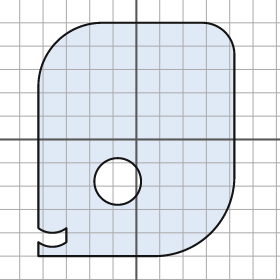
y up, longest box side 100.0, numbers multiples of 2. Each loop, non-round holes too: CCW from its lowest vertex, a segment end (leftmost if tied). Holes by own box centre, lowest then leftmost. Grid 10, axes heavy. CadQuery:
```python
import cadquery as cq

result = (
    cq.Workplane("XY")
    .moveTo(-42.0, -50.0)
    .lineTo(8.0, -50.0)
    .threePointArc((32.0, -40.0), (42.0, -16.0))
    .lineTo(42.0, 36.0)
    .threePointArc((38.0, 46.0), (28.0, 50.0))
    .lineTo(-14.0, 50.0)
    .threePointArc((-34.0, 42.0), (-42.0, 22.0))
    .lineTo(-42.0, -38.0)
    .threePointArc((-36.0, -40.0), (-30.0, -38.0))
    .lineTo(-30.0, -44.0)
    .threePointArc((-36.0, -46.0), (-42.0, -44.0))
    .close()
    .moveTo(-8.0, -18.0)
    .circle(10.0)
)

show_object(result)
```